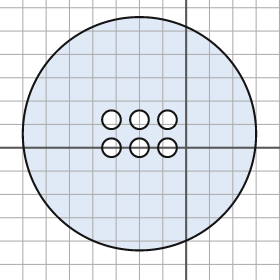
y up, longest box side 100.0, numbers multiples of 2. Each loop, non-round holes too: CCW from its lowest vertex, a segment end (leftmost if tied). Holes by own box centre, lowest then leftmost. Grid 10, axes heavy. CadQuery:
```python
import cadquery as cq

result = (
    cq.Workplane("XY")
    .moveTo(-20.0, 6.0)
    .circle(50.0)
    .moveTo(-32.0, 0.0)
    .circle(4.0)
    .moveTo(-20.0, 0.0)
    .circle(4.0)
    .moveTo(-8.0, 0.0)
    .circle(4.0)
    .moveTo(-32.0, 12.0)
    .circle(4.0)
    .moveTo(-20.0, 12.0)
    .circle(4.0)
    .moveTo(-8.0, 12.0)
    .circle(4.0)
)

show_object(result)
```